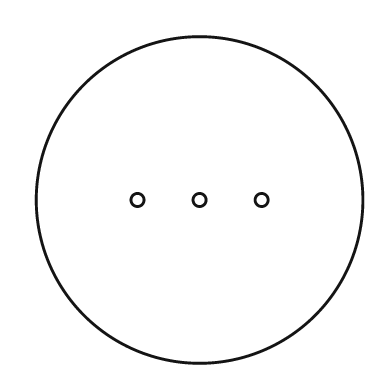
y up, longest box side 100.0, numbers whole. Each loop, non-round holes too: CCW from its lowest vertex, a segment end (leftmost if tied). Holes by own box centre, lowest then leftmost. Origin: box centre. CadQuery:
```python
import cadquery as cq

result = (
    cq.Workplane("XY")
    .moveTo(0.0, 0.0)
    .circle(50.0)
    .moveTo(-19.0, 0.0)
    .circle(2.0)
    .moveTo(0.0, 0.0)
    .circle(2.0)
    .moveTo(19.0, 0.0)
    .circle(2.0)
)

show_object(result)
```